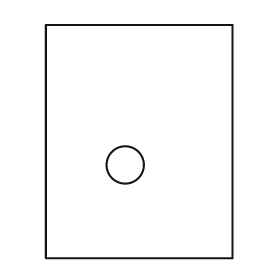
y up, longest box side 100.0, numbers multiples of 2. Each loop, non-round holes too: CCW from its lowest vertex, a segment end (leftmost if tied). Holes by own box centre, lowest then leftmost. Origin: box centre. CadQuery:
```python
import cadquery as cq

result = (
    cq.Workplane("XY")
    .moveTo(-40.0, -50.0)
    .lineTo(40.0, -50.0)
    .lineTo(40.0, 50.0)
    .lineTo(-40.0, 50.0)
    .close()
    .moveTo(-6.0, -10.0)
    .circle(8.0)
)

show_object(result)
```